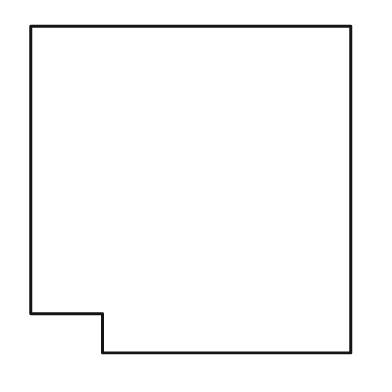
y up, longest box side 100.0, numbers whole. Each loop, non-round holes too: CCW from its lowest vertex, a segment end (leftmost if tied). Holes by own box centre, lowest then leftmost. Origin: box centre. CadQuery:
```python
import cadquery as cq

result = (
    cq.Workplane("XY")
    .moveTo(-27.0, -50.0)
    .lineTo(49.0, -50.0)
    .lineTo(49.0, 50.0)
    .lineTo(-49.0, 50.0)
    .lineTo(-49.0, -38.0)
    .lineTo(-27.0, -38.0)
    .close()
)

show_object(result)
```